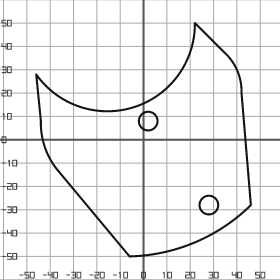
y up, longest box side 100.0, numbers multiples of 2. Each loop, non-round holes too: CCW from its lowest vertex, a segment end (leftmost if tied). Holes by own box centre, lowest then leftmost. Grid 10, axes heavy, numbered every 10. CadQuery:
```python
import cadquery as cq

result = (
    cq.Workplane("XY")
    .moveTo(-6.0, -50.0)
    .threePointArc((22.0, -44.0), (46.0, -28.0))
    .lineTo(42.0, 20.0)
    .threePointArc((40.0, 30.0), (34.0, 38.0))
    .lineTo(22.0, 50.0)
    .threePointArc((-4.0, 14.0), (-46.0, 28.0))
    .lineTo(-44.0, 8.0)
    .threePointArc((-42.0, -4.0), (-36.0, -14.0))
    .close()
    .moveTo(28.0, -28.0)
    .circle(4.0)
    .moveTo(2.0, 8.0)
    .circle(4.0)
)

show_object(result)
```